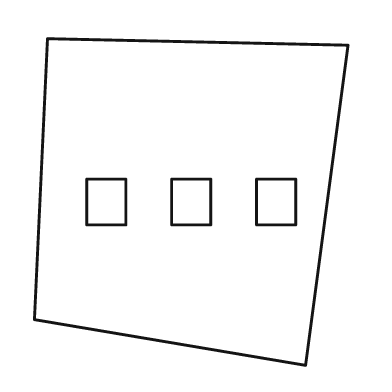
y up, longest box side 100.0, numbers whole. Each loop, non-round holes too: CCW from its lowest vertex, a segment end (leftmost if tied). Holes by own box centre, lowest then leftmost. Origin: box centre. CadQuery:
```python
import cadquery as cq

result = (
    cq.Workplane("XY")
    .moveTo(35.0, -50.0)
    .lineTo(48.0, 48.0)
    .lineTo(-44.0, 50.0)
    .lineTo(-48.0, -36.0)
    .close()
    .moveTo(-32.0, -7.0)
    .lineTo(-20.0, -7.0)
    .lineTo(-20.0, 7.0)
    .lineTo(-32.0, 7.0)
    .close()
    .moveTo(-6.0, -7.0)
    .lineTo(6.0, -7.0)
    .lineTo(6.0, 7.0)
    .lineTo(-6.0, 7.0)
    .close()
    .moveTo(20.0, -7.0)
    .lineTo(32.0, -7.0)
    .lineTo(32.0, 7.0)
    .lineTo(20.0, 7.0)
    .close()
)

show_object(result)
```